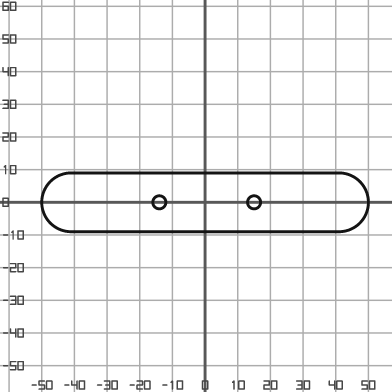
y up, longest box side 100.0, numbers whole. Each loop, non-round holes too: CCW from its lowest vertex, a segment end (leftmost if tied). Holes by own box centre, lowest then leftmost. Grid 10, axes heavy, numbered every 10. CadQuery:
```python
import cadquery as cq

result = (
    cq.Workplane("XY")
    .moveTo(-41.0, -9.0)
    .lineTo(41.0, -9.0)
    .threePointArc((50.0, 0.0), (41.0, 9.0))
    .lineTo(-41.0, 9.0)
    .threePointArc((-50.0, 0.0), (-41.0, -9.0))
    .close()
    .moveTo(-14.0, 0.0)
    .circle(2.0)
    .moveTo(15.0, 0.0)
    .circle(2.0)
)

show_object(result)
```